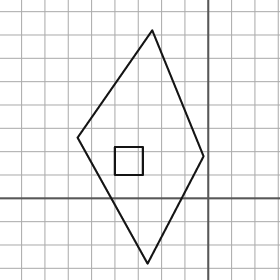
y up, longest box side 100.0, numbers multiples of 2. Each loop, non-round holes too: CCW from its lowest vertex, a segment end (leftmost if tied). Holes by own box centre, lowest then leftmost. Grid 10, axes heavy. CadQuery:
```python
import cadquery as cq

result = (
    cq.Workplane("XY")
    .moveTo(-26.0, -28.0)
    .lineTo(-2.0, 18.0)
    .lineTo(-24.0, 72.0)
    .lineTo(-56.0, 26.0)
    .close()
    .moveTo(-40.0, 10.0)
    .lineTo(-28.0, 10.0)
    .lineTo(-28.0, 22.0)
    .lineTo(-40.0, 22.0)
    .close()
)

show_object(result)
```